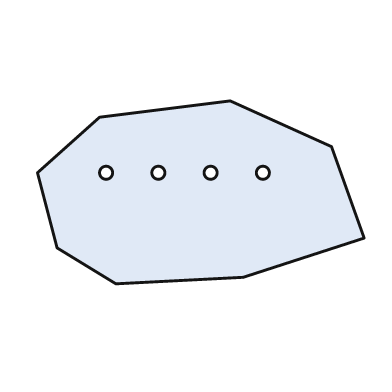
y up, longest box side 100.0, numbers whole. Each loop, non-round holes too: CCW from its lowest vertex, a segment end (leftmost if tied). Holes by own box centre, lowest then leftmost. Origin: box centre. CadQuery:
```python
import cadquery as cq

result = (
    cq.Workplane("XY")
    .moveTo(-26.0, -28.0)
    .lineTo(13.0, -26.0)
    .lineTo(50.0, -14.0)
    .lineTo(40.0, 14.0)
    .lineTo(9.0, 28.0)
    .lineTo(-31.0, 23.0)
    .lineTo(-50.0, 6.0)
    .lineTo(-44.0, -17.0)
    .close()
    .moveTo(-29.0, 6.0)
    .circle(2.0)
    .moveTo(-13.0, 6.0)
    .circle(2.0)
    .moveTo(3.0, 6.0)
    .circle(2.0)
    .moveTo(19.0, 6.0)
    .circle(2.0)
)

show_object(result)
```